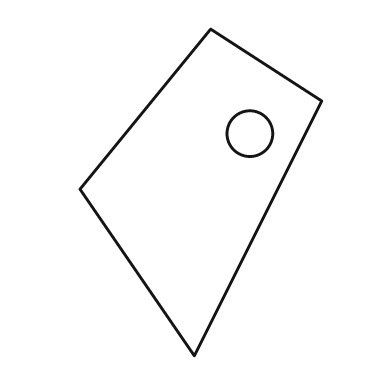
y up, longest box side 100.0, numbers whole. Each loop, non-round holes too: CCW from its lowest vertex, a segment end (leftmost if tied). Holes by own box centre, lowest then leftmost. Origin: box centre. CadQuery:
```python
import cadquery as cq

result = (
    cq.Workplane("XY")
    .moveTo(-2.0, -50.0)
    .lineTo(37.0, 28.0)
    .lineTo(3.0, 50.0)
    .lineTo(-37.0, 1.0)
    .close()
    .moveTo(15.0, 18.0)
    .circle(7.0)
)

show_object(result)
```